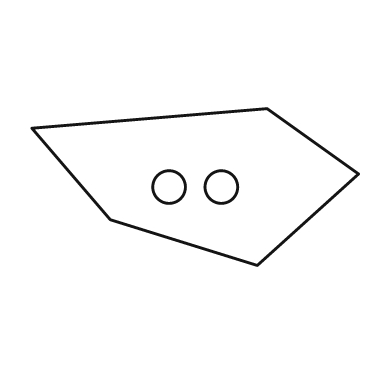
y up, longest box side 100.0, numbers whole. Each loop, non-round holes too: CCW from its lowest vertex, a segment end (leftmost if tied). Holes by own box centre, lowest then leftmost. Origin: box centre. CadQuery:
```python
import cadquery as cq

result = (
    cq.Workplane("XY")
    .moveTo(19.0, -24.0)
    .lineTo(50.0, 4.0)
    .lineTo(22.0, 24.0)
    .lineTo(-50.0, 18.0)
    .lineTo(-26.0, -10.0)
    .close()
    .moveTo(-8.0, 0.0)
    .circle(5.0)
    .moveTo(8.0, 0.0)
    .circle(5.0)
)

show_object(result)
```